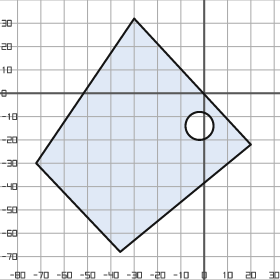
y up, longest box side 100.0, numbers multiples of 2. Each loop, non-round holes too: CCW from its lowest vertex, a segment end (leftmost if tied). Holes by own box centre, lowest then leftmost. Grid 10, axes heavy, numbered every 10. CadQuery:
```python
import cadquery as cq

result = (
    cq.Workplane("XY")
    .moveTo(-36.0, -68.0)
    .lineTo(20.0, -22.0)
    .lineTo(-30.0, 32.0)
    .lineTo(-72.0, -30.0)
    .close()
    .moveTo(-2.0, -14.0)
    .circle(6.0)
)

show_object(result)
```